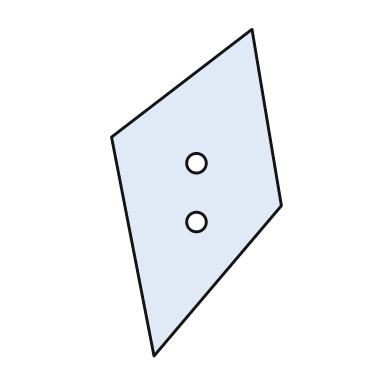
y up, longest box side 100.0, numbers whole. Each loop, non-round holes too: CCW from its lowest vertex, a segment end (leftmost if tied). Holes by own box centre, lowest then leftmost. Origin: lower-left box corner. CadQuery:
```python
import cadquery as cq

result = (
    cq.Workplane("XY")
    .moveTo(13.0, 0.0)
    .lineTo(52.0, 46.0)
    .lineTo(43.0, 100.0)
    .lineTo(0.0, 67.0)
    .close()
    .moveTo(26.0, 41.0)
    .circle(3.0)
    .moveTo(26.0, 59.0)
    .circle(3.0)
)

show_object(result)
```